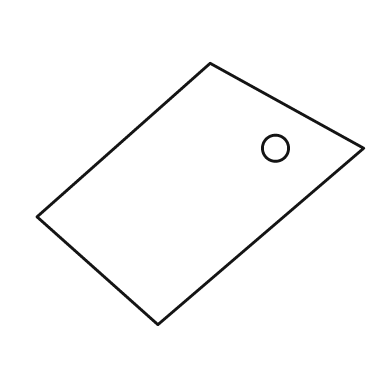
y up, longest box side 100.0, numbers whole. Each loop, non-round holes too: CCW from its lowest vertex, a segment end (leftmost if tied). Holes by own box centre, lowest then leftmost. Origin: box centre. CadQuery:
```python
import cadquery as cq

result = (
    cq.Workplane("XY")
    .moveTo(-13.0, -40.0)
    .lineTo(50.0, 14.0)
    .lineTo(3.0, 40.0)
    .lineTo(-50.0, -7.0)
    .close()
    .moveTo(23.0, 14.0)
    .circle(4.0)
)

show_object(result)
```